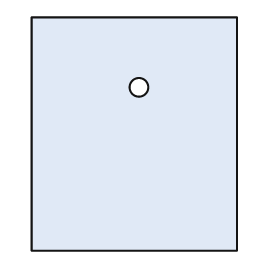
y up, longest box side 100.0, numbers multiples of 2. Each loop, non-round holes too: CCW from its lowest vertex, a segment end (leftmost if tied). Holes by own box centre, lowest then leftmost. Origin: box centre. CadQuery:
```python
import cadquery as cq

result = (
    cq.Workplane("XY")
    .moveTo(-44.0, -50.0)
    .lineTo(44.0, -50.0)
    .lineTo(44.0, 50.0)
    .lineTo(-44.0, 50.0)
    .close()
    .moveTo(2.0, 20.0)
    .circle(4.0)
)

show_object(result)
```